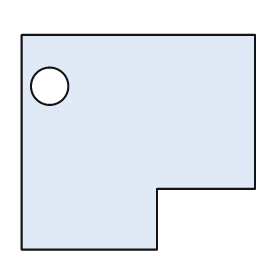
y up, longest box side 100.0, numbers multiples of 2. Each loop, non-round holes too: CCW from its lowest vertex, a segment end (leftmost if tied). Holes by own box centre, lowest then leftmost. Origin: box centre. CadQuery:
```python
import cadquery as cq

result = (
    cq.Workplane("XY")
    .moveTo(-50.0, -46.0)
    .lineTo(8.0, -46.0)
    .lineTo(8.0, -20.0)
    .lineTo(50.0, -20.0)
    .lineTo(50.0, 46.0)
    .lineTo(-50.0, 46.0)
    .close()
    .moveTo(-38.0, 24.0)
    .circle(8.0)
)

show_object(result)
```